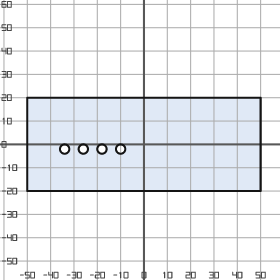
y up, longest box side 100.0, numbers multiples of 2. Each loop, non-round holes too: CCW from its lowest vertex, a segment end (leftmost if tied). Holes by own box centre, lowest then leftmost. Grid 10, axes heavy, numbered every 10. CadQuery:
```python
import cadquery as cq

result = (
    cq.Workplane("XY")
    .moveTo(-50.0, -20.0)
    .lineTo(50.0, -20.0)
    .lineTo(50.0, 20.0)
    .lineTo(-50.0, 20.0)
    .close()
    .moveTo(-34.0, -2.0)
    .circle(2.0)
    .moveTo(-26.0, -2.0)
    .circle(2.0)
    .moveTo(-18.0, -2.0)
    .circle(2.0)
    .moveTo(-10.0, -2.0)
    .circle(2.0)
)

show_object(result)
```